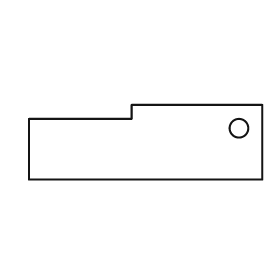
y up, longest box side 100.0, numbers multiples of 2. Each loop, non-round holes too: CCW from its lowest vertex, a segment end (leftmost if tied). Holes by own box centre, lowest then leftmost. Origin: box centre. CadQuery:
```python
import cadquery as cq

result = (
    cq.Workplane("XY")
    .moveTo(-50.0, -16.0)
    .lineTo(50.0, -16.0)
    .lineTo(50.0, 16.0)
    .lineTo(-6.0, 16.0)
    .lineTo(-6.0, 10.0)
    .lineTo(-50.0, 10.0)
    .close()
    .moveTo(40.0, 6.0)
    .circle(4.0)
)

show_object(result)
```